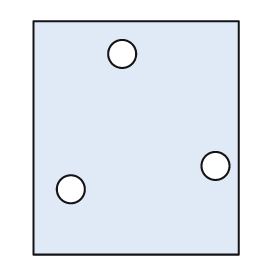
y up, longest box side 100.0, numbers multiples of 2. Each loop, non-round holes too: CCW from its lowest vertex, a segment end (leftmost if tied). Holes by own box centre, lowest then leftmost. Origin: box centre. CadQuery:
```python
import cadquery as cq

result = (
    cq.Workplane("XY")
    .moveTo(-44.0, -50.0)
    .lineTo(44.0, -50.0)
    .lineTo(44.0, 50.0)
    .lineTo(-44.0, 50.0)
    .close()
    .moveTo(-28.0, -22.0)
    .circle(6.0)
    .moveTo(34.0, -12.0)
    .circle(6.0)
    .moveTo(-6.0, 36.0)
    .circle(6.0)
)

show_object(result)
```